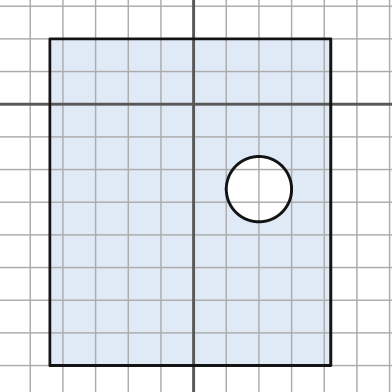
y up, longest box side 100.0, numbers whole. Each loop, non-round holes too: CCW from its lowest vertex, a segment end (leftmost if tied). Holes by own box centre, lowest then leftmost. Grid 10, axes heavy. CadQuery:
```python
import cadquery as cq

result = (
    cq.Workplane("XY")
    .moveTo(-44.0, -80.0)
    .lineTo(42.0, -80.0)
    .lineTo(42.0, 20.0)
    .lineTo(-44.0, 20.0)
    .close()
    .moveTo(20.0, -26.0)
    .circle(10.0)
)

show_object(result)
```